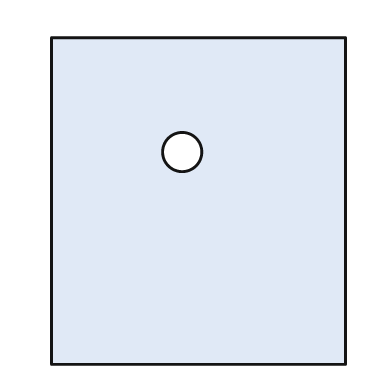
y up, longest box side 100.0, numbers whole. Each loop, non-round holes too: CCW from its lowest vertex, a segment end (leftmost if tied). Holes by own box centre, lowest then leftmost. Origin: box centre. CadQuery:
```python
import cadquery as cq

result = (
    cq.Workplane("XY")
    .moveTo(-45.0, -50.0)
    .lineTo(45.0, -50.0)
    .lineTo(45.0, 50.0)
    .lineTo(-45.0, 50.0)
    .close()
    .moveTo(-5.0, 15.0)
    .circle(6.0)
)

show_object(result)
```